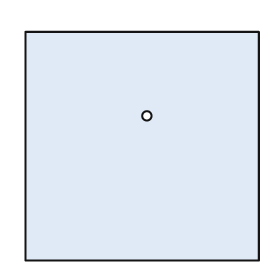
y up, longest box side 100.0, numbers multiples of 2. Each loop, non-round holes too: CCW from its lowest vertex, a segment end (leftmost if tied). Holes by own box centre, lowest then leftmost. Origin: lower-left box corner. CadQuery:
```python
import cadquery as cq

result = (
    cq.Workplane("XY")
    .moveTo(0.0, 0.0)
    .lineTo(100.0, 0.0)
    .lineTo(100.0, 98.0)
    .lineTo(0.0, 98.0)
    .close()
    .moveTo(52.0, 62.0)
    .circle(2.0)
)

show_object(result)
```